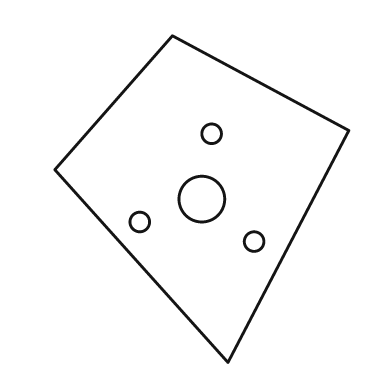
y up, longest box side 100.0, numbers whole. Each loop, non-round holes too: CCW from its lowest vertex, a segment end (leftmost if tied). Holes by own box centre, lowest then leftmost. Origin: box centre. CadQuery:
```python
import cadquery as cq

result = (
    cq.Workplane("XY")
    .moveTo(8.0, -50.0)
    .lineTo(45.0, 21.0)
    .lineTo(-9.0, 50.0)
    .lineTo(-45.0, 9.0)
    .close()
    .moveTo(16.0, -13.0)
    .circle(3.0)
    .moveTo(-19.0, -7.0)
    .circle(3.0)
    .moveTo(0.0, 0.0)
    .circle(7.0)
    .moveTo(3.0, 20.0)
    .circle(3.0)
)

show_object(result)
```